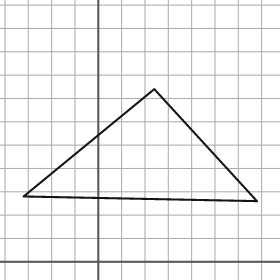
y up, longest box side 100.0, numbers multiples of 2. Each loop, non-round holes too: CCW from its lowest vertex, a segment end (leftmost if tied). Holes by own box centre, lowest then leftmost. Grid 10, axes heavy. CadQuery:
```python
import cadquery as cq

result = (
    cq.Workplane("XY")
    .moveTo(68.0, 26.0)
    .lineTo(24.0, 74.0)
    .lineTo(-32.0, 28.0)
    .close()
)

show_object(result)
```